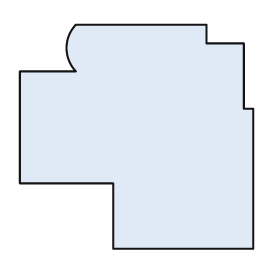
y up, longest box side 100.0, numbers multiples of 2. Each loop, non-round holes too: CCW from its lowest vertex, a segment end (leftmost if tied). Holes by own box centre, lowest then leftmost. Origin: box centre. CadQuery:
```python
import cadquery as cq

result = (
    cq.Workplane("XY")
    .moveTo(-10.0, -48.0)
    .lineTo(50.0, -48.0)
    .lineTo(50.0, 12.0)
    .lineTo(46.0, 12.0)
    .lineTo(46.0, 40.0)
    .lineTo(30.0, 40.0)
    .lineTo(30.0, 48.0)
    .lineTo(-26.0, 48.0)
    .threePointArc((-30.0, 38.0), (-26.0, 28.0))
    .lineTo(-50.0, 28.0)
    .lineTo(-50.0, -20.0)
    .lineTo(-10.0, -20.0)
    .close()
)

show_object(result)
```